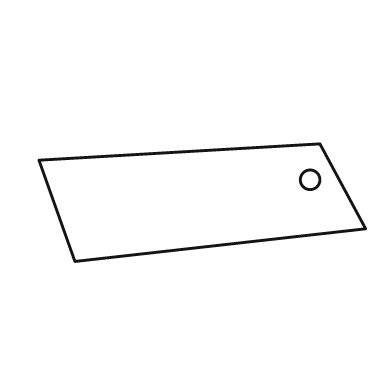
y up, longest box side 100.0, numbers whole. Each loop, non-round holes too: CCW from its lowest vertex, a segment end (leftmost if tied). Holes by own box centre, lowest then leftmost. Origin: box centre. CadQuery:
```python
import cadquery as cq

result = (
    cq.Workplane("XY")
    .moveTo(-39.0, -18.0)
    .lineTo(50.0, -8.0)
    .lineTo(36.0, 18.0)
    .lineTo(-50.0, 13.0)
    .close()
    .moveTo(33.0, 7.0)
    .circle(3.0)
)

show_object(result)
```